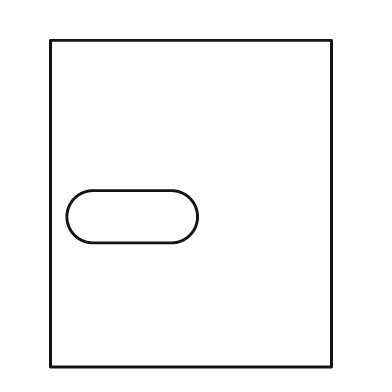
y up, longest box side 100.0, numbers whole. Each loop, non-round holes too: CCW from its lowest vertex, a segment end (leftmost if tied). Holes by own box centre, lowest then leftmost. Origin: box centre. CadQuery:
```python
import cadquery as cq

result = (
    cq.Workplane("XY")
    .moveTo(-43.0, -50.0)
    .lineTo(43.0, -50.0)
    .lineTo(43.0, 50.0)
    .lineTo(-43.0, 50.0)
    .close()
    .moveTo(-30.0, -12.0)
    .lineTo(-6.0, -12.0)
    .threePointArc((2.0, -4.0), (-6.0, 4.0))
    .lineTo(-30.0, 4.0)
    .threePointArc((-38.0, -4.0), (-30.0, -12.0))
    .close()
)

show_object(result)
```